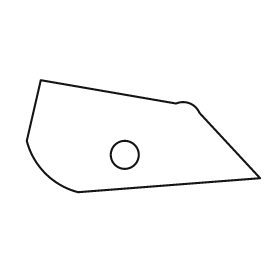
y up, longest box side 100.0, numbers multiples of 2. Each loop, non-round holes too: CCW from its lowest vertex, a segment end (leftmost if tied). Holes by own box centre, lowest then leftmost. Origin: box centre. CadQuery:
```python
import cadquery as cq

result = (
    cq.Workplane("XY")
    .moveTo(-28.0, -24.0)
    .lineTo(50.0, -18.0)
    .lineTo(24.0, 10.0)
    .threePointArc((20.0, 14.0), (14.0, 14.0))
    .lineTo(-44.0, 24.0)
    .lineTo(-50.0, -2.0)
    .threePointArc((-42.0, -16.0), (-28.0, -24.0))
    .close()
    .moveTo(-8.0, -8.0)
    .circle(6.0)
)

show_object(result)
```